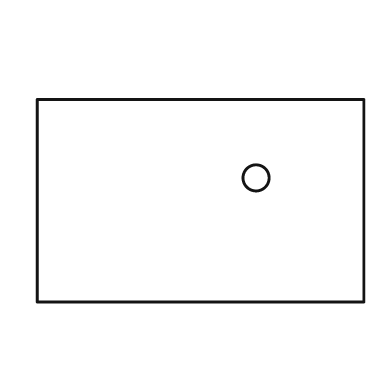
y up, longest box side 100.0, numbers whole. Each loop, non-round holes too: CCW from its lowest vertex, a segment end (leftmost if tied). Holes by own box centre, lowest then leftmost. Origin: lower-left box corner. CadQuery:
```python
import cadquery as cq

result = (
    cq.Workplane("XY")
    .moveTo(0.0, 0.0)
    .lineTo(100.0, 0.0)
    .lineTo(100.0, 62.0)
    .lineTo(0.0, 62.0)
    .close()
    .moveTo(67.0, 38.0)
    .circle(4.0)
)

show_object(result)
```